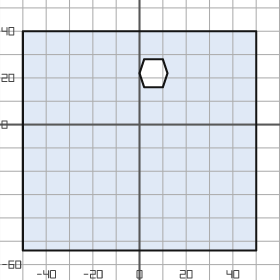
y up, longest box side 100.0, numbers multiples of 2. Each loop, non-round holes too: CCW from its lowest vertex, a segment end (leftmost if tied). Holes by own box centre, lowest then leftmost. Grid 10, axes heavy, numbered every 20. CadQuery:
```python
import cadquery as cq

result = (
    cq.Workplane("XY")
    .moveTo(-50.0, -54.0)
    .lineTo(50.0, -54.0)
    .lineTo(50.0, 40.0)
    .lineTo(-50.0, 40.0)
    .close()
    .moveTo(2.0, 16.0)
    .lineTo(10.0, 16.0)
    .lineTo(12.0, 22.0)
    .lineTo(10.0, 28.0)
    .lineTo(2.0, 28.0)
    .lineTo(0.0, 22.0)
    .close()
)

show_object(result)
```